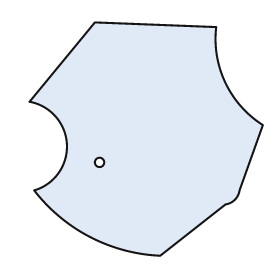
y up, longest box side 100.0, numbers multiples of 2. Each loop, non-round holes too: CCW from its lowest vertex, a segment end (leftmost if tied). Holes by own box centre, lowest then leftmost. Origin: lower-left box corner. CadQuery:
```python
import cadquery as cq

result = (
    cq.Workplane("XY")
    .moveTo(56.0, 0.0)
    .lineTo(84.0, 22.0)
    .threePointArc((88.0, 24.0), (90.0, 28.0))
    .lineTo(100.0, 56.0)
    .threePointArc((84.0, 74.0), (80.0, 98.0))
    .lineTo(28.0, 100.0)
    .lineTo(0.0, 66.0)
    .threePointArc((16.0, 48.0), (2.0, 28.0))
    .threePointArc((26.0, 8.0), (56.0, 0.0))
    .close()
    .moveTo(30.0, 40.0)
    .circle(2.0)
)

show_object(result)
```